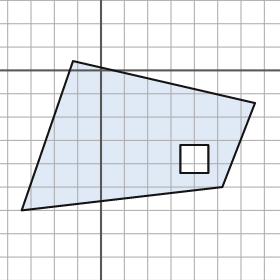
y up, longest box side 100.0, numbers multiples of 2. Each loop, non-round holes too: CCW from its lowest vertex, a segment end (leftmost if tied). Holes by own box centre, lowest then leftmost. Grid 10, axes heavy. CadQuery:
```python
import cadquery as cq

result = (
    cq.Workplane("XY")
    .moveTo(-34.0, -60.0)
    .lineTo(52.0, -50.0)
    .lineTo(66.0, -14.0)
    .lineTo(-12.0, 4.0)
    .close()
    .moveTo(34.0, -44.0)
    .lineTo(46.0, -44.0)
    .lineTo(46.0, -32.0)
    .lineTo(34.0, -32.0)
    .close()
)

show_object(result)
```